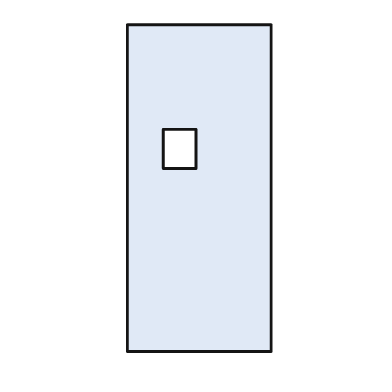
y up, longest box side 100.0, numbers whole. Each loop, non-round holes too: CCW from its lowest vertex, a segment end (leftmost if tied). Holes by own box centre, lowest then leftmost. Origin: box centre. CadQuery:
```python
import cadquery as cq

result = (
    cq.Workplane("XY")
    .moveTo(-22.0, -50.0)
    .lineTo(22.0, -50.0)
    .lineTo(22.0, 50.0)
    .lineTo(-22.0, 50.0)
    .close()
    .moveTo(-11.0, 6.0)
    .lineTo(-1.0, 6.0)
    .lineTo(-1.0, 18.0)
    .lineTo(-11.0, 18.0)
    .close()
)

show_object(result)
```